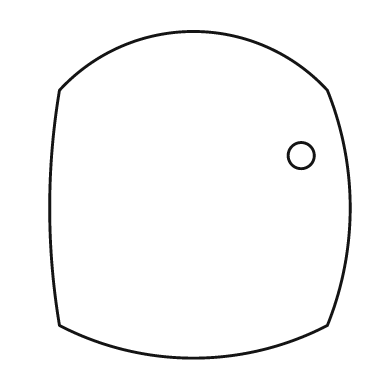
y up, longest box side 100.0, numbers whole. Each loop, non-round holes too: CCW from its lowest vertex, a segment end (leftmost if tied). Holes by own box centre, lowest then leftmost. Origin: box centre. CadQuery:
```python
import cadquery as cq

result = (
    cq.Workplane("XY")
    .moveTo(-43.0, -40.0)
    .threePointArc((-2.0, -50.0), (39.0, -40.0))
    .threePointArc((46.0, -4.0), (39.0, 32.0))
    .threePointArc((-2.0, 50.0), (-43.0, 32.0))
    .threePointArc((-46.0, -4.0), (-43.0, -40.0))
    .close()
    .moveTo(31.0, 12.0)
    .circle(4.0)
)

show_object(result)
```